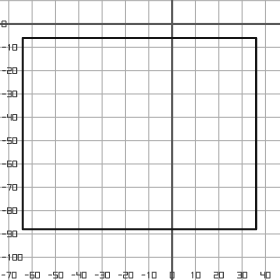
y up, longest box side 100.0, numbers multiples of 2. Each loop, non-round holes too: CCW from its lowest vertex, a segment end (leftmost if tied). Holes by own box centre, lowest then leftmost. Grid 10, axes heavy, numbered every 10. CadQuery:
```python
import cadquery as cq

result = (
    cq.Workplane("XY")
    .moveTo(-64.0, -88.0)
    .lineTo(36.0, -88.0)
    .lineTo(36.0, -6.0)
    .lineTo(-64.0, -6.0)
    .close()
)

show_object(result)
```